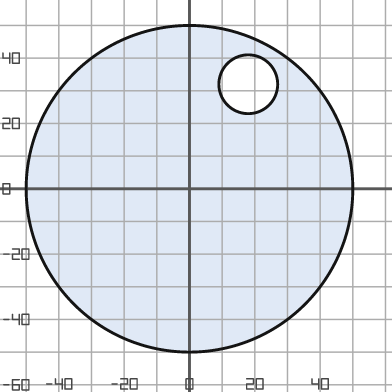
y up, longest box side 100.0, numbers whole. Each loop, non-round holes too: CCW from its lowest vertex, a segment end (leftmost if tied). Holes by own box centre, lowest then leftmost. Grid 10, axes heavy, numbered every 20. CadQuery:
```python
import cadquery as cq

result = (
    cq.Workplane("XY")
    .moveTo(0.0, 0.0)
    .circle(50.0)
    .moveTo(18.0, 32.0)
    .circle(9.0)
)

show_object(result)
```